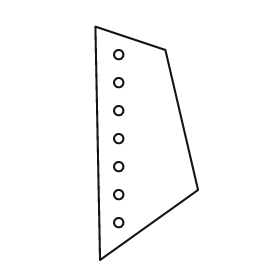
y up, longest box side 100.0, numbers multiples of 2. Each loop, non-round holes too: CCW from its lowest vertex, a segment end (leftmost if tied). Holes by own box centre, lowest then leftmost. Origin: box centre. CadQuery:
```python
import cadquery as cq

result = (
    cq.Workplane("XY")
    .moveTo(-20.0, -50.0)
    .lineTo(22.0, -20.0)
    .lineTo(8.0, 40.0)
    .lineTo(-22.0, 50.0)
    .close()
    .moveTo(-12.0, -34.0)
    .circle(2.0)
    .moveTo(-12.0, -22.0)
    .circle(2.0)
    .moveTo(-12.0, -10.0)
    .circle(2.0)
    .moveTo(-12.0, 2.0)
    .circle(2.0)
    .moveTo(-12.0, 14.0)
    .circle(2.0)
    .moveTo(-12.0, 26.0)
    .circle(2.0)
    .moveTo(-12.0, 38.0)
    .circle(2.0)
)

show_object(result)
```